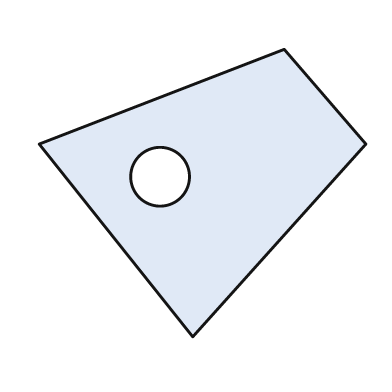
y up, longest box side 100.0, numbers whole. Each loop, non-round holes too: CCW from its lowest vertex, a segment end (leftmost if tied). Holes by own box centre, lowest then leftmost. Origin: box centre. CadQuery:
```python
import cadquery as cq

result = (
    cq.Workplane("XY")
    .moveTo(-3.0, -44.0)
    .lineTo(50.0, 15.0)
    .lineTo(25.0, 44.0)
    .lineTo(-50.0, 15.0)
    .close()
    .moveTo(-13.0, 5.0)
    .circle(9.0)
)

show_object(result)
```